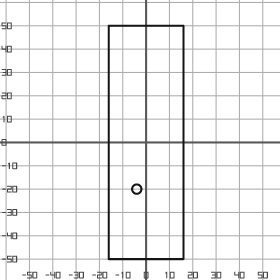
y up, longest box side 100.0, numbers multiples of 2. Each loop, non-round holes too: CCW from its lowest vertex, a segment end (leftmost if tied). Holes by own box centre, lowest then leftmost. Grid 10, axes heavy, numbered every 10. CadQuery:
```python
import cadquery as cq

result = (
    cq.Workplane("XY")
    .moveTo(-16.0, -50.0)
    .lineTo(16.0, -50.0)
    .lineTo(16.0, 50.0)
    .lineTo(-16.0, 50.0)
    .close()
    .moveTo(-4.0, -20.0)
    .circle(2.0)
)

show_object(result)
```